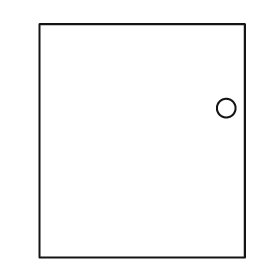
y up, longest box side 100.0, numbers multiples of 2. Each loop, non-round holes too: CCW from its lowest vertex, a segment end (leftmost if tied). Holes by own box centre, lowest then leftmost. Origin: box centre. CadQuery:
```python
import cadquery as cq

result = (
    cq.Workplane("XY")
    .moveTo(-44.0, -50.0)
    .lineTo(44.0, -50.0)
    .lineTo(44.0, 50.0)
    .lineTo(-44.0, 50.0)
    .close()
    .moveTo(36.0, 14.0)
    .circle(4.0)
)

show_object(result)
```